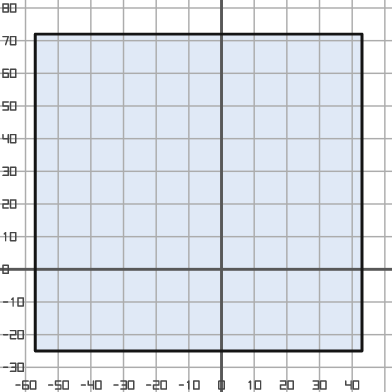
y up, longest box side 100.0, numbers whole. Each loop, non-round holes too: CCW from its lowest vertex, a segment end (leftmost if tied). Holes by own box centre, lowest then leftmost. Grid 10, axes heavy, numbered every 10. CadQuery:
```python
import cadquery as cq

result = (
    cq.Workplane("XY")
    .moveTo(-57.0, -25.0)
    .lineTo(43.0, -25.0)
    .lineTo(43.0, 72.0)
    .lineTo(-57.0, 72.0)
    .close()
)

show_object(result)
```